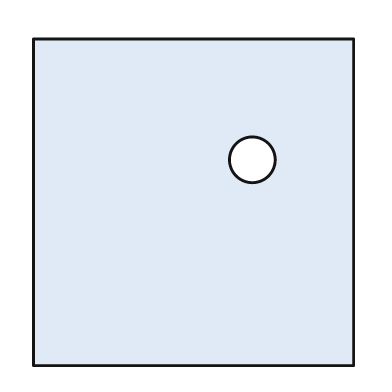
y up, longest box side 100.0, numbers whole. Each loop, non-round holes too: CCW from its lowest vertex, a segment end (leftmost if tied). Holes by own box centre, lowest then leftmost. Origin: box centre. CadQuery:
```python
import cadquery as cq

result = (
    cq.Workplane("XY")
    .moveTo(-49.0, -50.0)
    .lineTo(49.0, -50.0)
    .lineTo(49.0, 50.0)
    .lineTo(-49.0, 50.0)
    .close()
    .moveTo(18.0, 13.0)
    .circle(7.0)
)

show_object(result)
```